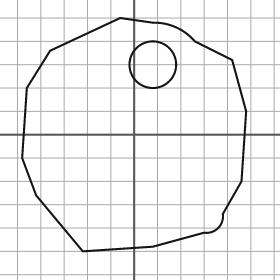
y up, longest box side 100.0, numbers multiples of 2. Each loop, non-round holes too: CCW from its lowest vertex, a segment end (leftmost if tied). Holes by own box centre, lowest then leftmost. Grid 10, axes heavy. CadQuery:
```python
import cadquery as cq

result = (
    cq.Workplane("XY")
    .moveTo(-22.0, -50.0)
    .lineTo(8.0, -48.0)
    .lineTo(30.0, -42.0)
    .threePointArc((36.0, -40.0), (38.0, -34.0))
    .lineTo(46.0, -20.0)
    .lineTo(48.0, 10.0)
    .lineTo(42.0, 32.0)
    .lineTo(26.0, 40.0)
    .threePointArc((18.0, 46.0), (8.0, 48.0))
    .lineTo(-6.0, 50.0)
    .lineTo(-36.0, 36.0)
    .lineTo(-46.0, 20.0)
    .lineTo(-48.0, -10.0)
    .lineTo(-42.0, -26.0)
    .close()
    .moveTo(8.0, 30.0)
    .circle(10.0)
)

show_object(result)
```